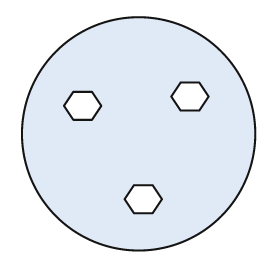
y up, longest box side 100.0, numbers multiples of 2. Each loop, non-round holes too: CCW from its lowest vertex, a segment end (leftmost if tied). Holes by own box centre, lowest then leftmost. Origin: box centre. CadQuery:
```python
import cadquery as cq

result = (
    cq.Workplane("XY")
    .moveTo(0.0, 0.0)
    .circle(50.0)
    .moveTo(-2.0, -34.0)
    .lineTo(6.0, -34.0)
    .lineTo(10.0, -28.0)
    .lineTo(6.0, -22.0)
    .lineTo(-2.0, -22.0)
    .lineTo(-6.0, -28.0)
    .close()
    .moveTo(-28.0, 6.0)
    .lineTo(-20.0, 6.0)
    .lineTo(-16.0, 12.0)
    .lineTo(-20.0, 18.0)
    .lineTo(-28.0, 18.0)
    .lineTo(-32.0, 12.0)
    .close()
    .moveTo(18.0, 10.0)
    .lineTo(26.0, 10.0)
    .lineTo(30.0, 16.0)
    .lineTo(26.0, 22.0)
    .lineTo(18.0, 22.0)
    .lineTo(14.0, 16.0)
    .close()
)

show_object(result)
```